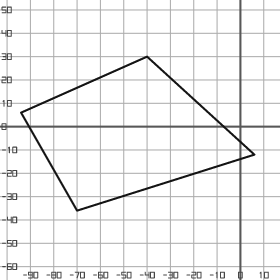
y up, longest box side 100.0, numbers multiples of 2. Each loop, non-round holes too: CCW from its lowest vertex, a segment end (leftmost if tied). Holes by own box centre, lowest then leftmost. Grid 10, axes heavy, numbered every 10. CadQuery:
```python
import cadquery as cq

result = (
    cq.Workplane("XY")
    .moveTo(-70.0, -36.0)
    .lineTo(6.0, -12.0)
    .lineTo(-40.0, 30.0)
    .lineTo(-94.0, 6.0)
    .close()
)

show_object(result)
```